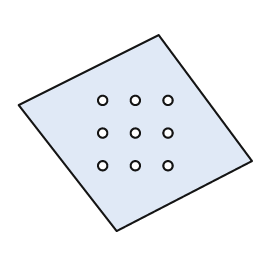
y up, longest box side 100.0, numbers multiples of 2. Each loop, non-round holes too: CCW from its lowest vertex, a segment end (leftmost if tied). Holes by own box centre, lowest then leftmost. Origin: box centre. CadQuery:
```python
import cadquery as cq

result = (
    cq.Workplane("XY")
    .moveTo(-8.0, -42.0)
    .lineTo(50.0, -12.0)
    .lineTo(10.0, 42.0)
    .lineTo(-50.0, 12.0)
    .close()
    .moveTo(-14.0, -14.0)
    .circle(2.0)
    .moveTo(0.0, -14.0)
    .circle(2.0)
    .moveTo(14.0, -14.0)
    .circle(2.0)
    .moveTo(-14.0, 0.0)
    .circle(2.0)
    .moveTo(0.0, 0.0)
    .circle(2.0)
    .moveTo(14.0, 0.0)
    .circle(2.0)
    .moveTo(-14.0, 14.0)
    .circle(2.0)
    .moveTo(0.0, 14.0)
    .circle(2.0)
    .moveTo(14.0, 14.0)
    .circle(2.0)
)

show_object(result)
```